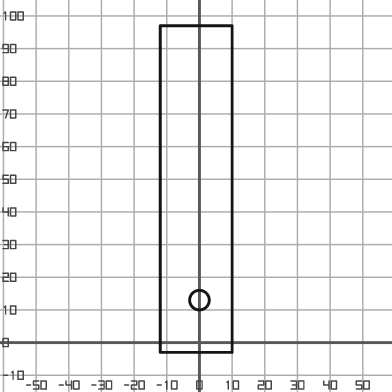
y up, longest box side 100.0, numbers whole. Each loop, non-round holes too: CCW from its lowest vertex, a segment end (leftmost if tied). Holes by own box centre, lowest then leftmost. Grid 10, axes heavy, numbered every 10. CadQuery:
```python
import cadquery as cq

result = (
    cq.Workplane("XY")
    .moveTo(-12.0, -3.0)
    .lineTo(10.0, -3.0)
    .lineTo(10.0, 97.0)
    .lineTo(-12.0, 97.0)
    .close()
    .moveTo(0.0, 13.0)
    .circle(3.0)
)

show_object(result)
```